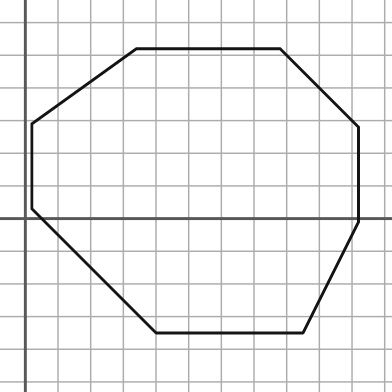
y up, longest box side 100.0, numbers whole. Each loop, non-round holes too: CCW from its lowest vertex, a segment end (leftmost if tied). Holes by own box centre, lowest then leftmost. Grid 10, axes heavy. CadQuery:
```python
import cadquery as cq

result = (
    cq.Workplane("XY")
    .moveTo(40.0, -35.0)
    .lineTo(85.0, -35.0)
    .lineTo(102.0, -1.0)
    .lineTo(102.0, 28.0)
    .lineTo(78.0, 52.0)
    .lineTo(34.0, 52.0)
    .lineTo(2.0, 29.0)
    .lineTo(2.0, 3.0)
    .close()
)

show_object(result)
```